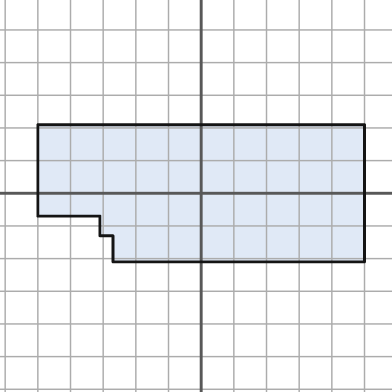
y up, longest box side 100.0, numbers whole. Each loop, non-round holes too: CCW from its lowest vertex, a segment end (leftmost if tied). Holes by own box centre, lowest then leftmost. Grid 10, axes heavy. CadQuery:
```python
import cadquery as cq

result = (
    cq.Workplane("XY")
    .moveTo(-27.0, -21.0)
    .lineTo(50.0, -21.0)
    .lineTo(50.0, 21.0)
    .lineTo(-50.0, 21.0)
    .lineTo(-50.0, -7.0)
    .lineTo(-31.0, -7.0)
    .lineTo(-31.0, -13.0)
    .lineTo(-27.0, -13.0)
    .close()
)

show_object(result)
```